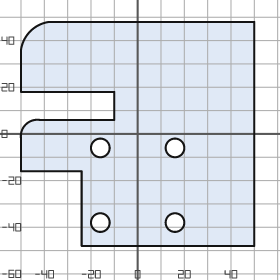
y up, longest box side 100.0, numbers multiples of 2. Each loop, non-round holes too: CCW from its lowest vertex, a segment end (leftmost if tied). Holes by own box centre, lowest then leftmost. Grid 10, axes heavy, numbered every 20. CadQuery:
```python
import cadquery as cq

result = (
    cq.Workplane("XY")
    .moveTo(-24.0, -48.0)
    .lineTo(50.0, -48.0)
    .lineTo(50.0, 48.0)
    .lineTo(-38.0, 48.0)
    .threePointArc((-46.0, 44.0), (-50.0, 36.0))
    .lineTo(-50.0, 18.0)
    .lineTo(-10.0, 18.0)
    .lineTo(-10.0, 6.0)
    .lineTo(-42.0, 6.0)
    .threePointArc((-48.0, 4.0), (-50.0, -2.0))
    .lineTo(-50.0, -16.0)
    .lineTo(-24.0, -16.0)
    .close()
    .moveTo(-16.0, -38.0)
    .circle(4.0)
    .moveTo(16.0, -38.0)
    .circle(4.0)
    .moveTo(-16.0, -6.0)
    .circle(4.0)
    .moveTo(16.0, -6.0)
    .circle(4.0)
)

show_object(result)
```